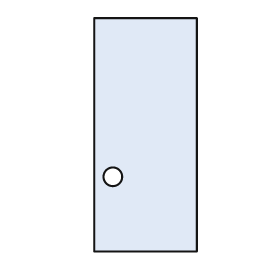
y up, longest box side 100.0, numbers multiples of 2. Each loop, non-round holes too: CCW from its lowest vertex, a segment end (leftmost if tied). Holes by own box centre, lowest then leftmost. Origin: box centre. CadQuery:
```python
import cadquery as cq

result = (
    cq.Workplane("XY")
    .moveTo(-22.0, -50.0)
    .lineTo(22.0, -50.0)
    .lineTo(22.0, 50.0)
    .lineTo(-22.0, 50.0)
    .close()
    .moveTo(-14.0, -18.0)
    .circle(4.0)
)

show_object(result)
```